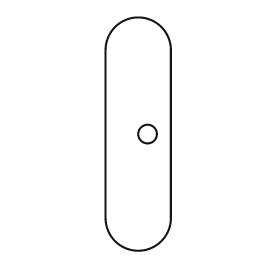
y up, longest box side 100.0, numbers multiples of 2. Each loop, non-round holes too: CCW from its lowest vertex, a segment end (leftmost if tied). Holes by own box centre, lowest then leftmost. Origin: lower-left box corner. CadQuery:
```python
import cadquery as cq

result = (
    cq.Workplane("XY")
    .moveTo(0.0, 14.0)
    .threePointArc((14.0, 0.0), (28.0, 14.0))
    .lineTo(28.0, 86.0)
    .threePointArc((14.0, 100.0), (0.0, 86.0))
    .close()
    .moveTo(18.0, 50.0)
    .circle(4.0)
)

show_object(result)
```